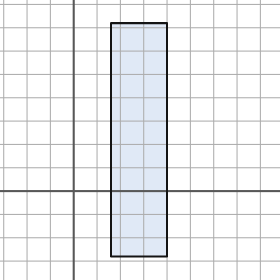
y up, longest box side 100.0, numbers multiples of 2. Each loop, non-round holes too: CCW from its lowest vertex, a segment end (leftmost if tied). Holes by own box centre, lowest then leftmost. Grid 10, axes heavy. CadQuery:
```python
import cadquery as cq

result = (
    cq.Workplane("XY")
    .moveTo(16.0, -28.0)
    .lineTo(40.0, -28.0)
    .lineTo(40.0, 72.0)
    .lineTo(16.0, 72.0)
    .close()
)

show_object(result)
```